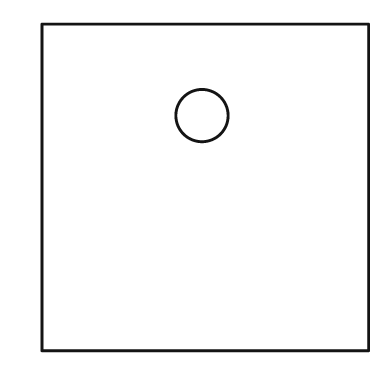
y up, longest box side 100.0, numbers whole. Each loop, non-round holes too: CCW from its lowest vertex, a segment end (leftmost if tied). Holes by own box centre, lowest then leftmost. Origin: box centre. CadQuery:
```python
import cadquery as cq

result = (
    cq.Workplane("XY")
    .moveTo(-50.0, -50.0)
    .lineTo(50.0, -50.0)
    .lineTo(50.0, 50.0)
    .lineTo(-50.0, 50.0)
    .close()
    .moveTo(-1.0, 22.0)
    .circle(8.0)
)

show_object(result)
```